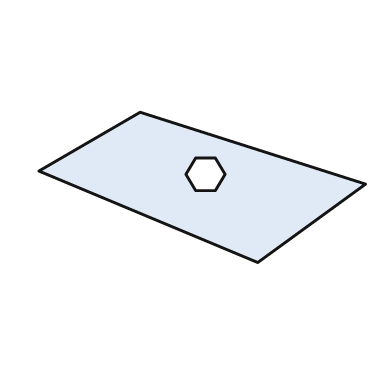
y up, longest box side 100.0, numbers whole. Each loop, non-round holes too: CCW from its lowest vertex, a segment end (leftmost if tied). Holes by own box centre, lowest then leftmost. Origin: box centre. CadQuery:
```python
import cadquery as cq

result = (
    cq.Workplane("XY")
    .moveTo(17.0, -23.0)
    .lineTo(50.0, 1.0)
    .lineTo(-19.0, 23.0)
    .lineTo(-50.0, 5.0)
    .close()
    .moveTo(-2.0, -1.0)
    .lineTo(4.0, -1.0)
    .lineTo(7.0, 4.0)
    .lineTo(4.0, 9.0)
    .lineTo(-2.0, 9.0)
    .lineTo(-5.0, 4.0)
    .close()
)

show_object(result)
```